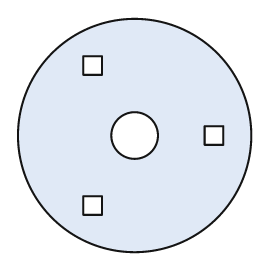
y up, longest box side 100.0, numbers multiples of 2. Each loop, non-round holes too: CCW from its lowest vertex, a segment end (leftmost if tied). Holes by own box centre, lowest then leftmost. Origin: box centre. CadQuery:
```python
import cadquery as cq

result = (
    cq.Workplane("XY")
    .moveTo(0.0, 0.0)
    .circle(50.0)
    .moveTo(-22.0, -34.0)
    .lineTo(-14.0, -34.0)
    .lineTo(-14.0, -26.0)
    .lineTo(-22.0, -26.0)
    .close()
    .moveTo(0.0, 0.0)
    .circle(10.0)
    .moveTo(30.0, -4.0)
    .lineTo(38.0, -4.0)
    .lineTo(38.0, 4.0)
    .lineTo(30.0, 4.0)
    .close()
    .moveTo(-22.0, 26.0)
    .lineTo(-14.0, 26.0)
    .lineTo(-14.0, 34.0)
    .lineTo(-22.0, 34.0)
    .close()
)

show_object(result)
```